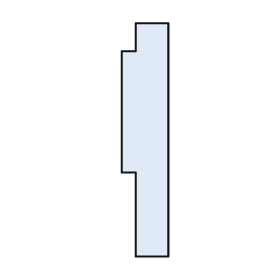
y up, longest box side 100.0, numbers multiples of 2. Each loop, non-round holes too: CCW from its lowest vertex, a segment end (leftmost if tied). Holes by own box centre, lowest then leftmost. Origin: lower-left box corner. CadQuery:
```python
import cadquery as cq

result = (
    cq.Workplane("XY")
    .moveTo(6.0, 0.0)
    .lineTo(20.0, 0.0)
    .lineTo(20.0, 100.0)
    .lineTo(6.0, 100.0)
    .lineTo(6.0, 88.0)
    .lineTo(0.0, 88.0)
    .lineTo(0.0, 36.0)
    .lineTo(6.0, 36.0)
    .close()
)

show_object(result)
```